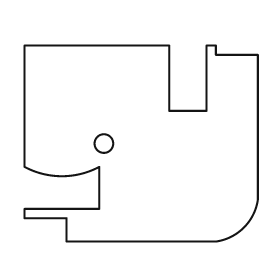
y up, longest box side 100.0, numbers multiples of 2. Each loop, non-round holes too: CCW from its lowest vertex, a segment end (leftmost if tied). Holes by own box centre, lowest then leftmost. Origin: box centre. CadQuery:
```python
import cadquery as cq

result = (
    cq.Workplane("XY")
    .moveTo(-32.0, -42.0)
    .lineTo(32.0, -42.0)
    .threePointArc((44.0, -36.0), (50.0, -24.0))
    .lineTo(50.0, 38.0)
    .lineTo(32.0, 38.0)
    .lineTo(32.0, 42.0)
    .lineTo(28.0, 42.0)
    .lineTo(28.0, 14.0)
    .lineTo(12.0, 14.0)
    .lineTo(12.0, 42.0)
    .lineTo(-50.0, 42.0)
    .lineTo(-50.0, -10.0)
    .threePointArc((-34.0, -14.0), (-18.0, -10.0))
    .lineTo(-18.0, -28.0)
    .lineTo(-50.0, -28.0)
    .lineTo(-50.0, -32.0)
    .lineTo(-32.0, -32.0)
    .close()
    .moveTo(-16.0, 0.0)
    .circle(4.0)
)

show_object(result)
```